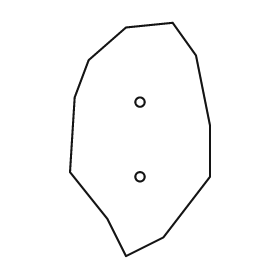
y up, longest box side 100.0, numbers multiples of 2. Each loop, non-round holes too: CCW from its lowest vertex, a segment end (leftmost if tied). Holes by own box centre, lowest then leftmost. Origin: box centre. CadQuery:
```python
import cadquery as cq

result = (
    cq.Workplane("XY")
    .moveTo(-6.0, -50.0)
    .lineTo(10.0, -42.0)
    .lineTo(30.0, -16.0)
    .lineTo(30.0, 6.0)
    .lineTo(24.0, 36.0)
    .lineTo(14.0, 50.0)
    .lineTo(-6.0, 48.0)
    .lineTo(-22.0, 34.0)
    .lineTo(-28.0, 18.0)
    .lineTo(-30.0, -14.0)
    .lineTo(-14.0, -34.0)
    .close()
    .moveTo(0.0, -16.0)
    .circle(2.0)
    .moveTo(0.0, 16.0)
    .circle(2.0)
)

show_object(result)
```